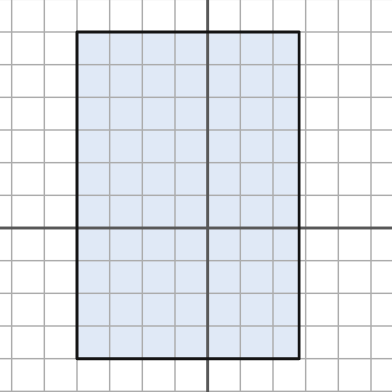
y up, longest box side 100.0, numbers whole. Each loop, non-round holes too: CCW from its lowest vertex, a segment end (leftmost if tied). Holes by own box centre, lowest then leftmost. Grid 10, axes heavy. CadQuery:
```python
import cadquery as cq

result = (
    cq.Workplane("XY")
    .moveTo(-40.0, -40.0)
    .lineTo(28.0, -40.0)
    .lineTo(28.0, 60.0)
    .lineTo(-40.0, 60.0)
    .close()
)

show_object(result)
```